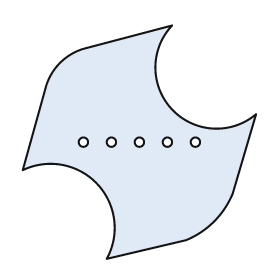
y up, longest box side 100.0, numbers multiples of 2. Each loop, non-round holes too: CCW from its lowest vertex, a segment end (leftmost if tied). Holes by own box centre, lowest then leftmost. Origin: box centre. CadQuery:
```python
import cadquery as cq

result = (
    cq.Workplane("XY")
    .moveTo(-14.0, -50.0)
    .lineTo(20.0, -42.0)
    .threePointArc((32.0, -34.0), (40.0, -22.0))
    .lineTo(50.0, 12.0)
    .threePointArc((14.0, 14.0), (14.0, 50.0))
    .lineTo(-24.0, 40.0)
    .threePointArc((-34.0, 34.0), (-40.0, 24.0))
    .lineTo(-50.0, -12.0)
    .threePointArc((-18.0, -18.0), (-14.0, -50.0))
    .close()
    .moveTo(-24.0, 0.0)
    .circle(2.0)
    .moveTo(-12.0, 0.0)
    .circle(2.0)
    .moveTo(0.0, 0.0)
    .circle(2.0)
    .moveTo(12.0, 0.0)
    .circle(2.0)
    .moveTo(24.0, 0.0)
    .circle(2.0)
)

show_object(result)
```